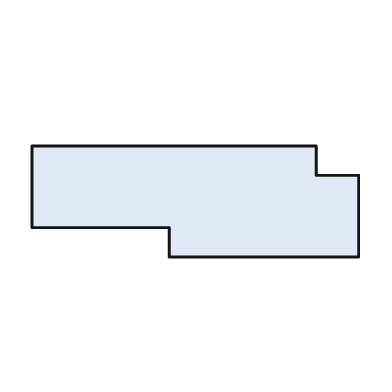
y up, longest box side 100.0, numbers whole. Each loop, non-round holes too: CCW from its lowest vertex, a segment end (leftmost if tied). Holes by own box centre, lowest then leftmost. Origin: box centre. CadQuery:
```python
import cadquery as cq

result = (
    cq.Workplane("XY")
    .moveTo(-8.0, -17.0)
    .lineTo(50.0, -17.0)
    .lineTo(50.0, 8.0)
    .lineTo(37.0, 8.0)
    .lineTo(37.0, 17.0)
    .lineTo(-50.0, 17.0)
    .lineTo(-50.0, -8.0)
    .lineTo(-8.0, -8.0)
    .close()
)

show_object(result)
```